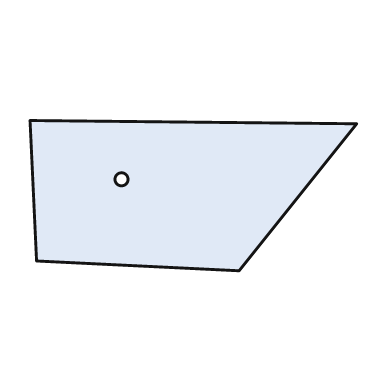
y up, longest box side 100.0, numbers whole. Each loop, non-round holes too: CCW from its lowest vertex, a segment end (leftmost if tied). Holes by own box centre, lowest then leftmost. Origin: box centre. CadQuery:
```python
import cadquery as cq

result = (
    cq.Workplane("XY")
    .moveTo(14.0, -23.0)
    .lineTo(50.0, 22.0)
    .lineTo(-50.0, 23.0)
    .lineTo(-48.0, -20.0)
    .close()
    .moveTo(-22.0, 5.0)
    .circle(2.0)
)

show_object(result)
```